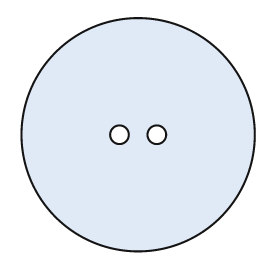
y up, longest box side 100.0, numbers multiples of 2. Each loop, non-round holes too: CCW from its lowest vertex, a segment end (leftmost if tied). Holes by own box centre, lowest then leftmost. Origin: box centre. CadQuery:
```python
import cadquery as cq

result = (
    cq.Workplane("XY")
    .moveTo(0.0, 0.0)
    .circle(50.0)
    .moveTo(-8.0, 0.0)
    .circle(4.0)
    .moveTo(8.0, 0.0)
    .circle(4.0)
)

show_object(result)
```